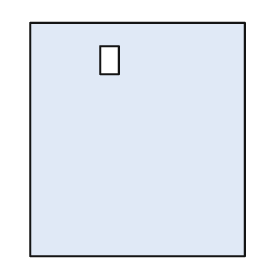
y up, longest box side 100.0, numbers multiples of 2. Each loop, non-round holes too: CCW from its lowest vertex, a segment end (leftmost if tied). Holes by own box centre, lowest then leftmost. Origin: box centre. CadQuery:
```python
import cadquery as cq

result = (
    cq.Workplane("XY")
    .moveTo(-46.0, -50.0)
    .lineTo(46.0, -50.0)
    .lineTo(46.0, 50.0)
    .lineTo(-46.0, 50.0)
    .close()
    .moveTo(-16.0, 28.0)
    .lineTo(-8.0, 28.0)
    .lineTo(-8.0, 40.0)
    .lineTo(-16.0, 40.0)
    .close()
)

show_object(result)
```